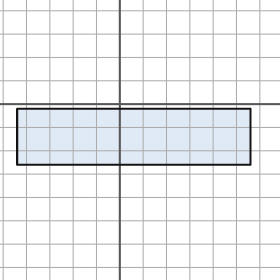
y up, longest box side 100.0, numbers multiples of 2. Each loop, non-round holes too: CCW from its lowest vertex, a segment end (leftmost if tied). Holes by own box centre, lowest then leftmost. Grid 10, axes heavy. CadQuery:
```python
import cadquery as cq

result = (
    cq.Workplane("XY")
    .moveTo(-44.0, -26.0)
    .lineTo(56.0, -26.0)
    .lineTo(56.0, -2.0)
    .lineTo(-44.0, -2.0)
    .close()
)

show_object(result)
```